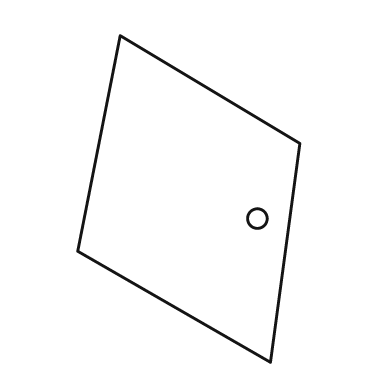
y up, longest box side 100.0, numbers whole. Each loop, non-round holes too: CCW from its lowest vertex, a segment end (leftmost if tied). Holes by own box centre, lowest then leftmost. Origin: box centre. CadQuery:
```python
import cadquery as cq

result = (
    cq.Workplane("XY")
    .moveTo(25.0, -50.0)
    .lineTo(34.0, 17.0)
    .lineTo(-21.0, 50.0)
    .lineTo(-34.0, -16.0)
    .close()
    .moveTo(21.0, -6.0)
    .circle(3.0)
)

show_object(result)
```